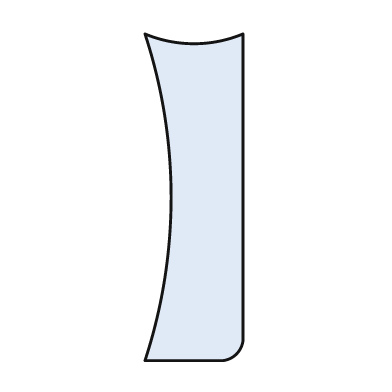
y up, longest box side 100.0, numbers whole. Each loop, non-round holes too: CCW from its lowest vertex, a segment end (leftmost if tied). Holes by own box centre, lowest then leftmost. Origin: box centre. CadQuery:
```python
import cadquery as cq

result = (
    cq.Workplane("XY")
    .moveTo(-15.0, -50.0)
    .lineTo(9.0, -50.0)
    .threePointArc((13.0, -48.0), (15.0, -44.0))
    .lineTo(15.0, 50.0)
    .threePointArc((0.0, 47.0), (-15.0, 50.0))
    .threePointArc((-7.0, 0.0), (-15.0, -50.0))
    .close()
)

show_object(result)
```